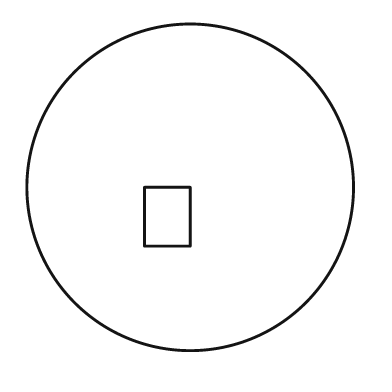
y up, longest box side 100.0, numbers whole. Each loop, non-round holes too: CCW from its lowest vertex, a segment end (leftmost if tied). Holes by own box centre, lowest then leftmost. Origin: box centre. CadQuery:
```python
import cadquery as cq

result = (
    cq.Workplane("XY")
    .moveTo(0.0, 0.0)
    .circle(50.0)
    .moveTo(-14.0, -18.0)
    .lineTo(0.0, -18.0)
    .lineTo(0.0, 0.0)
    .lineTo(-14.0, 0.0)
    .close()
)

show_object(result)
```